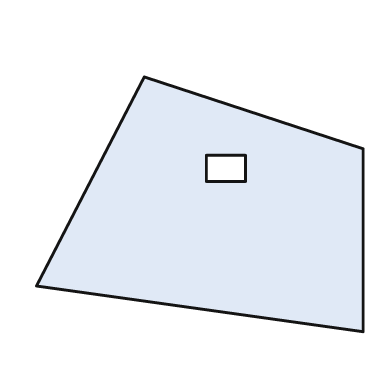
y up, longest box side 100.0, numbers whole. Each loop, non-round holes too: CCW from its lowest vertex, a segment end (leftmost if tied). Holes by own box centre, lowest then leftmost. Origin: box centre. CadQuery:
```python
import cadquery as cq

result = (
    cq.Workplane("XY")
    .moveTo(50.0, -39.0)
    .lineTo(50.0, 17.0)
    .lineTo(-17.0, 39.0)
    .lineTo(-50.0, -25.0)
    .close()
    .moveTo(2.0, 7.0)
    .lineTo(14.0, 7.0)
    .lineTo(14.0, 15.0)
    .lineTo(2.0, 15.0)
    .close()
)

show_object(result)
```